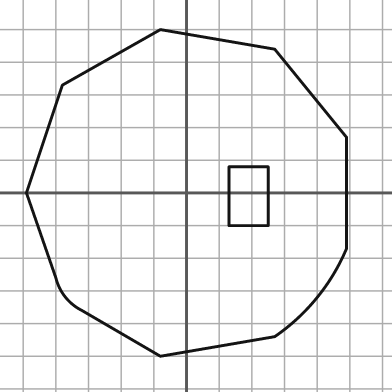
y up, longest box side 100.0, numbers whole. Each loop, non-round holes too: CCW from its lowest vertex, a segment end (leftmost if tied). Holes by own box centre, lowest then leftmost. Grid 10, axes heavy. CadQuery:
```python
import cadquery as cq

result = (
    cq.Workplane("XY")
    .moveTo(-8.0, -50.0)
    .lineTo(27.0, -44.0)
    .threePointArc((40.0, -32.0), (49.0, -17.0))
    .lineTo(49.0, 17.0)
    .lineTo(27.0, 44.0)
    .lineTo(-8.0, 50.0)
    .lineTo(-38.0, 33.0)
    .lineTo(-49.0, 0.0)
    .lineTo(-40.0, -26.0)
    .threePointArc((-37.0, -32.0), (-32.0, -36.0))
    .close()
    .moveTo(13.0, -10.0)
    .lineTo(25.0, -10.0)
    .lineTo(25.0, 8.0)
    .lineTo(13.0, 8.0)
    .close()
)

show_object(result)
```